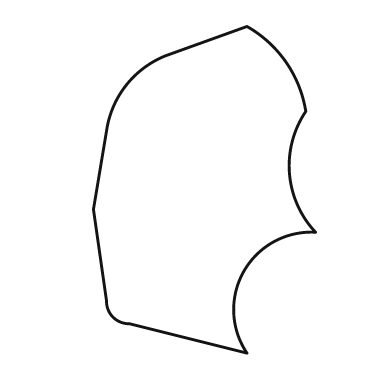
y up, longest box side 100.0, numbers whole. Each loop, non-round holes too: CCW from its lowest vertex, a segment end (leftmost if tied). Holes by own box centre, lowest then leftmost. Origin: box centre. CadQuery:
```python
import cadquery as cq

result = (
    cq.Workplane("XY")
    .moveTo(13.0, -50.0)
    .threePointArc((12.0, -25.0), (34.0, -13.0))
    .threePointArc((26.0, 5.0), (31.0, 24.0))
    .threePointArc((25.0, 39.0), (13.0, 50.0))
    .lineTo(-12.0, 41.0)
    .threePointArc((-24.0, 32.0), (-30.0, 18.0))
    .lineTo(-34.0, -6.0)
    .lineTo(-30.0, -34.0)
    .threePointArc((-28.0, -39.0), (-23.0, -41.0))
    .close()
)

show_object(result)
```